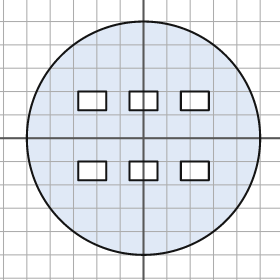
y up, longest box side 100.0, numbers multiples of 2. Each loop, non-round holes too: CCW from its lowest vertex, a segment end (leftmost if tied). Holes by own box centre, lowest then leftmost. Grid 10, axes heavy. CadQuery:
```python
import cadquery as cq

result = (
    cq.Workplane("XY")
    .moveTo(0.0, 0.0)
    .circle(50.0)
    .moveTo(-28.0, -18.0)
    .lineTo(-16.0, -18.0)
    .lineTo(-16.0, -10.0)
    .lineTo(-28.0, -10.0)
    .close()
    .moveTo(-6.0, -18.0)
    .lineTo(6.0, -18.0)
    .lineTo(6.0, -10.0)
    .lineTo(-6.0, -10.0)
    .close()
    .moveTo(16.0, -18.0)
    .lineTo(28.0, -18.0)
    .lineTo(28.0, -10.0)
    .lineTo(16.0, -10.0)
    .close()
    .moveTo(-28.0, 12.0)
    .lineTo(-16.0, 12.0)
    .lineTo(-16.0, 20.0)
    .lineTo(-28.0, 20.0)
    .close()
    .moveTo(-6.0, 12.0)
    .lineTo(6.0, 12.0)
    .lineTo(6.0, 20.0)
    .lineTo(-6.0, 20.0)
    .close()
    .moveTo(16.0, 12.0)
    .lineTo(28.0, 12.0)
    .lineTo(28.0, 20.0)
    .lineTo(16.0, 20.0)
    .close()
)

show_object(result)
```